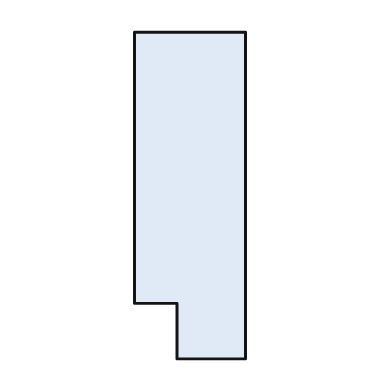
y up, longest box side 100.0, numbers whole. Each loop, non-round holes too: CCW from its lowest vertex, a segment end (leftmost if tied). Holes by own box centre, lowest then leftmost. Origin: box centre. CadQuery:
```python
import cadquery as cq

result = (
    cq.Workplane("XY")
    .moveTo(-4.0, -50.0)
    .lineTo(17.0, -50.0)
    .lineTo(17.0, 50.0)
    .lineTo(-17.0, 50.0)
    .lineTo(-17.0, -33.0)
    .lineTo(-4.0, -33.0)
    .close()
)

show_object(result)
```